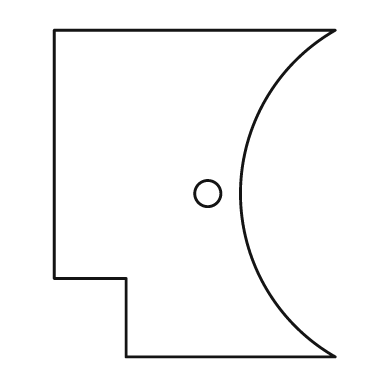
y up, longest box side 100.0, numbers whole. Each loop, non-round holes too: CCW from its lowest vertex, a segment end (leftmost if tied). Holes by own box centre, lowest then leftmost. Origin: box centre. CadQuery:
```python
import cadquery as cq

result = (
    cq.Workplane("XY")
    .moveTo(-21.0, -50.0)
    .lineTo(43.0, -50.0)
    .threePointArc((14.0, 0.0), (43.0, 50.0))
    .lineTo(-43.0, 50.0)
    .lineTo(-43.0, -26.0)
    .lineTo(-21.0, -26.0)
    .close()
    .moveTo(4.0, 0.0)
    .circle(4.0)
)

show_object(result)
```